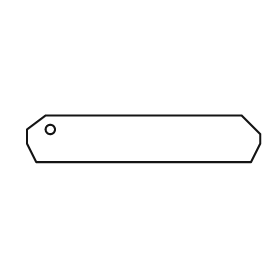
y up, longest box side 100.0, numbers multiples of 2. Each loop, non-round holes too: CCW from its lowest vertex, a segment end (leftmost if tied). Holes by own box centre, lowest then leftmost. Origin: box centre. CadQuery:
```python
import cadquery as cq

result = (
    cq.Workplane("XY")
    .moveTo(-46.0, -10.0)
    .lineTo(46.0, -10.0)
    .lineTo(50.0, -2.0)
    .lineTo(50.0, 2.0)
    .lineTo(42.0, 10.0)
    .lineTo(-42.0, 10.0)
    .lineTo(-50.0, 4.0)
    .lineTo(-50.0, -2.0)
    .close()
    .moveTo(-40.0, 4.0)
    .circle(2.0)
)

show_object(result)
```